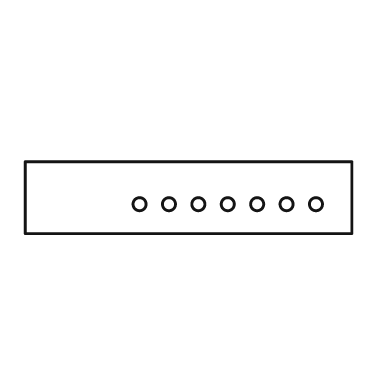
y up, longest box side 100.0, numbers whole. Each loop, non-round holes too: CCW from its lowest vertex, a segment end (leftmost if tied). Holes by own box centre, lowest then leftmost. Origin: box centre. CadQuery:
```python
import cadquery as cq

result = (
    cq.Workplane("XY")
    .moveTo(-50.0, -11.0)
    .lineTo(50.0, -11.0)
    .lineTo(50.0, 11.0)
    .lineTo(-50.0, 11.0)
    .close()
    .moveTo(-15.0, -2.0)
    .circle(2.0)
    .moveTo(-6.0, -2.0)
    .circle(2.0)
    .moveTo(3.0, -2.0)
    .circle(2.0)
    .moveTo(12.0, -2.0)
    .circle(2.0)
    .moveTo(21.0, -2.0)
    .circle(2.0)
    .moveTo(30.0, -2.0)
    .circle(2.0)
    .moveTo(39.0, -2.0)
    .circle(2.0)
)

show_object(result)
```